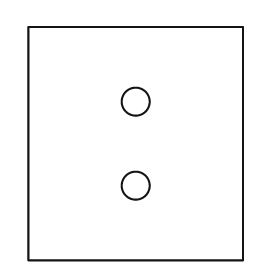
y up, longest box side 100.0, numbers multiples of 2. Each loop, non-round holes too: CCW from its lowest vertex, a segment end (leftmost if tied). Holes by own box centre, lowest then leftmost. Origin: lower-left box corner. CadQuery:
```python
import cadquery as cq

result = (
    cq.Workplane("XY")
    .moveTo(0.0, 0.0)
    .lineTo(92.0, 0.0)
    .lineTo(92.0, 100.0)
    .lineTo(0.0, 100.0)
    .close()
    .moveTo(46.0, 32.0)
    .circle(6.0)
    .moveTo(46.0, 68.0)
    .circle(6.0)
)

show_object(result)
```